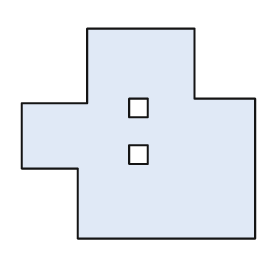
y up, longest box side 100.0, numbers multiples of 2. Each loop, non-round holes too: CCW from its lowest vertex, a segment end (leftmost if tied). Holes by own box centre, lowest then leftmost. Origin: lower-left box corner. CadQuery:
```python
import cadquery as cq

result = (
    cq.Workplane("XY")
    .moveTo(24.0, 0.0)
    .lineTo(100.0, 0.0)
    .lineTo(100.0, 60.0)
    .lineTo(74.0, 60.0)
    .lineTo(74.0, 90.0)
    .lineTo(28.0, 90.0)
    .lineTo(28.0, 58.0)
    .lineTo(0.0, 58.0)
    .lineTo(0.0, 30.0)
    .lineTo(24.0, 30.0)
    .close()
    .moveTo(46.0, 32.0)
    .lineTo(54.0, 32.0)
    .lineTo(54.0, 40.0)
    .lineTo(46.0, 40.0)
    .close()
    .moveTo(46.0, 52.0)
    .lineTo(54.0, 52.0)
    .lineTo(54.0, 60.0)
    .lineTo(46.0, 60.0)
    .close()
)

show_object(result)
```